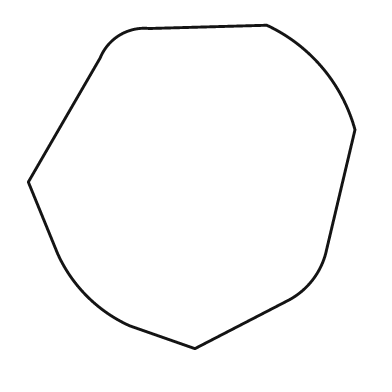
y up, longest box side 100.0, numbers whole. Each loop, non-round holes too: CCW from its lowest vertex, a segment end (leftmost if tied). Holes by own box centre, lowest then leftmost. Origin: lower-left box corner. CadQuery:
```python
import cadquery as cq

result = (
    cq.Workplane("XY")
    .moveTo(51.0, 0.0)
    .lineTo(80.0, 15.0)
    .threePointArc((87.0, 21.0), (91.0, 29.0))
    .lineTo(100.0, 67.0)
    .threePointArc((90.0, 86.0), (73.0, 99.0))
    .lineTo(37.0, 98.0)
    .threePointArc((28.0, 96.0), (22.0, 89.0))
    .lineTo(0.0, 51.0)
    .lineTo(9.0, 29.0)
    .threePointArc((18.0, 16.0), (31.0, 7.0))
    .close()
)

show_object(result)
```